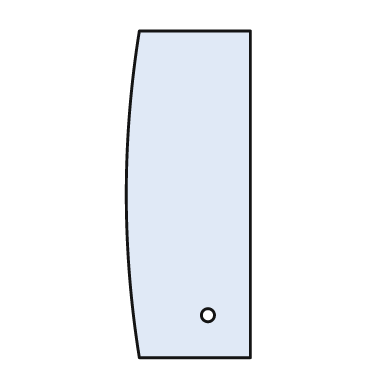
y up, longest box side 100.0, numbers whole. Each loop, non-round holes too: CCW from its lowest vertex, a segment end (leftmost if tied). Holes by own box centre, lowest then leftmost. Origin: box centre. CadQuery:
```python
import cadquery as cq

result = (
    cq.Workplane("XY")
    .moveTo(-15.0, -50.0)
    .lineTo(19.0, -50.0)
    .lineTo(19.0, 50.0)
    .lineTo(-15.0, 50.0)
    .threePointArc((-19.0, 0.0), (-15.0, -50.0))
    .close()
    .moveTo(6.0, -37.0)
    .circle(2.0)
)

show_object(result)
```